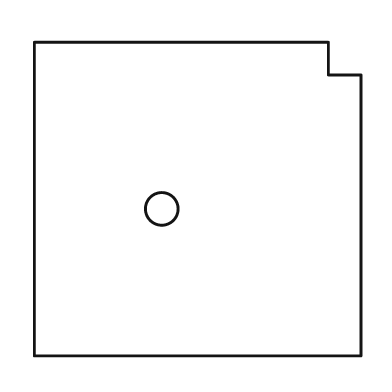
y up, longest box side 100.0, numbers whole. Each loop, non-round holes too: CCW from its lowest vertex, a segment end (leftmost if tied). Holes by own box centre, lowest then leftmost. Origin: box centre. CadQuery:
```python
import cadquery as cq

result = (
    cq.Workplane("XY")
    .moveTo(-50.0, -48.0)
    .lineTo(50.0, -48.0)
    .lineTo(50.0, 38.0)
    .lineTo(40.0, 38.0)
    .lineTo(40.0, 48.0)
    .lineTo(-50.0, 48.0)
    .close()
    .moveTo(-11.0, -3.0)
    .circle(5.0)
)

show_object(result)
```